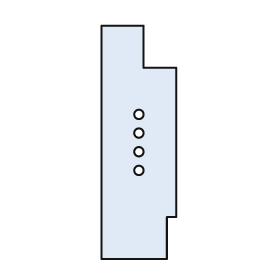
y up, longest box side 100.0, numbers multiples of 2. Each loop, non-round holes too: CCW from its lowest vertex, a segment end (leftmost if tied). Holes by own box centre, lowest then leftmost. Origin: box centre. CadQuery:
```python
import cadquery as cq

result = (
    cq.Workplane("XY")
    .moveTo(-16.0, -50.0)
    .lineTo(12.0, -50.0)
    .lineTo(12.0, -32.0)
    .lineTo(16.0, -32.0)
    .lineTo(16.0, 32.0)
    .lineTo(2.0, 32.0)
    .lineTo(2.0, 50.0)
    .lineTo(-16.0, 50.0)
    .close()
    .moveTo(0.0, -12.0)
    .circle(2.0)
    .moveTo(0.0, -4.0)
    .circle(2.0)
    .moveTo(0.0, 4.0)
    .circle(2.0)
    .moveTo(0.0, 12.0)
    .circle(2.0)
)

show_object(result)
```